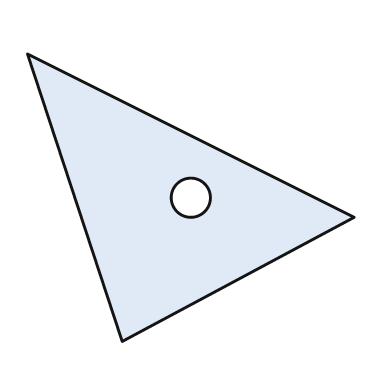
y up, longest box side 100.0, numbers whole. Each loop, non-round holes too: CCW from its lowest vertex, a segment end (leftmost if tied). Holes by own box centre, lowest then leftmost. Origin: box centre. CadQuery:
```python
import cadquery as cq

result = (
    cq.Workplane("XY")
    .moveTo(-21.0, -44.0)
    .lineTo(50.0, -6.0)
    .lineTo(-50.0, 44.0)
    .close()
    .moveTo(0.0, 0.0)
    .circle(6.0)
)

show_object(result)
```